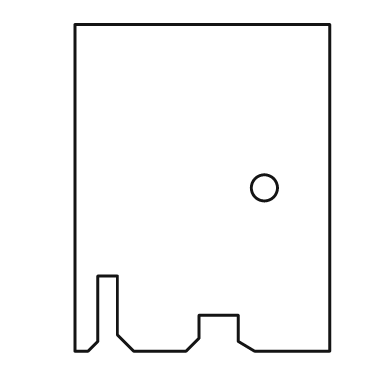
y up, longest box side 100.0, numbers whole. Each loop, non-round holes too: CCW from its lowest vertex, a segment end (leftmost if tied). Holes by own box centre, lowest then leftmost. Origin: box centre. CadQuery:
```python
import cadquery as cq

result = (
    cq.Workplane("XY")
    .moveTo(-39.0, -50.0)
    .lineTo(-35.0, -50.0)
    .lineTo(-32.0, -47.0)
    .lineTo(-32.0, -27.0)
    .lineTo(-26.0, -27.0)
    .lineTo(-26.0, -45.0)
    .lineTo(-21.0, -50.0)
    .lineTo(-5.0, -50.0)
    .lineTo(-1.0, -46.0)
    .lineTo(-1.0, -39.0)
    .lineTo(11.0, -39.0)
    .lineTo(11.0, -47.0)
    .lineTo(16.0, -50.0)
    .lineTo(39.0, -50.0)
    .lineTo(39.0, 50.0)
    .lineTo(-39.0, 50.0)
    .close()
    .moveTo(19.0, 0.0)
    .circle(4.0)
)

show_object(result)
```